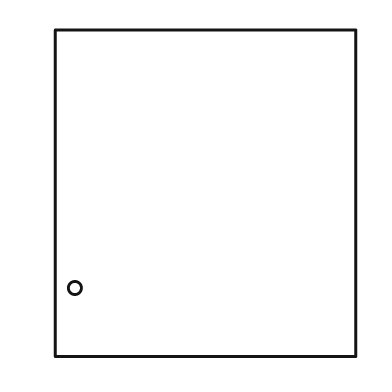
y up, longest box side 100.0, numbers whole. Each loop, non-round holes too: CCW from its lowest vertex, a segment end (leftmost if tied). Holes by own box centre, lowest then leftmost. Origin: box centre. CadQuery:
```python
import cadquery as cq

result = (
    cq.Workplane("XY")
    .moveTo(-46.0, -50.0)
    .lineTo(46.0, -50.0)
    .lineTo(46.0, 50.0)
    .lineTo(-46.0, 50.0)
    .close()
    .moveTo(-40.0, -29.0)
    .circle(2.0)
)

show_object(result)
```